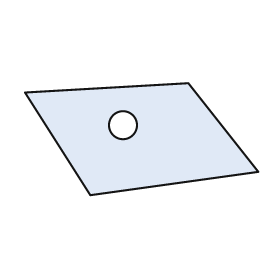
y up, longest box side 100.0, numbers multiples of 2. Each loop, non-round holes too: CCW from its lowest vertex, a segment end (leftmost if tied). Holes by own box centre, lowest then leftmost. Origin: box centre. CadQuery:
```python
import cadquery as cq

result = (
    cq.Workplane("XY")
    .moveTo(-22.0, -24.0)
    .lineTo(50.0, -14.0)
    .lineTo(20.0, 24.0)
    .lineTo(-50.0, 20.0)
    .close()
    .moveTo(-8.0, 6.0)
    .circle(6.0)
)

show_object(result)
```